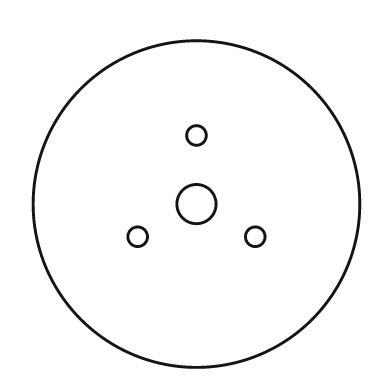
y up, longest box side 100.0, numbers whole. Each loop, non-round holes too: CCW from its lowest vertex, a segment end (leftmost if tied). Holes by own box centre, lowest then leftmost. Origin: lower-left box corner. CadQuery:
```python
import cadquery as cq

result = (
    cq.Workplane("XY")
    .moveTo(50.0, 50.0)
    .circle(50.0)
    .moveTo(32.0, 40.0)
    .circle(3.0)
    .moveTo(68.0, 40.0)
    .circle(3.0)
    .moveTo(50.0, 50.0)
    .circle(6.0)
    .moveTo(50.0, 71.0)
    .circle(3.0)
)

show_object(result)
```